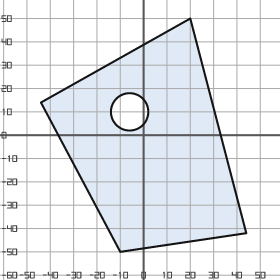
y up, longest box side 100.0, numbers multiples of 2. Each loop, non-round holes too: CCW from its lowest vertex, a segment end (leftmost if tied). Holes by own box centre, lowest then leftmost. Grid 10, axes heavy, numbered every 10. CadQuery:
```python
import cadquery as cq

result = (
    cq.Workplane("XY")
    .moveTo(-10.0, -50.0)
    .lineTo(44.0, -42.0)
    .lineTo(20.0, 50.0)
    .lineTo(-44.0, 14.0)
    .close()
    .moveTo(-6.0, 10.0)
    .circle(8.0)
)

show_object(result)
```